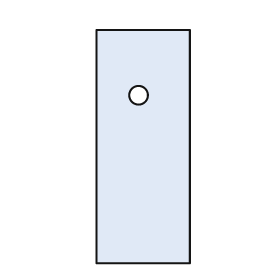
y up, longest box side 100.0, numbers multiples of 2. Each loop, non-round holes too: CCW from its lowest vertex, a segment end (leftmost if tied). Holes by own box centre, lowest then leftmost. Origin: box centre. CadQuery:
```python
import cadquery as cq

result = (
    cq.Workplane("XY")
    .moveTo(-20.0, -50.0)
    .lineTo(20.0, -50.0)
    .lineTo(20.0, 50.0)
    .lineTo(-20.0, 50.0)
    .close()
    .moveTo(-2.0, 22.0)
    .circle(4.0)
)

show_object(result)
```